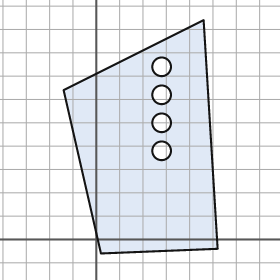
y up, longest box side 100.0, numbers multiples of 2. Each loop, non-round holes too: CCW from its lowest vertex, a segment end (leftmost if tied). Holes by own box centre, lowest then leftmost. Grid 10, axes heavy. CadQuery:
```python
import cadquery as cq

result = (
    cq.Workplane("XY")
    .moveTo(2.0, -6.0)
    .lineTo(52.0, -4.0)
    .lineTo(46.0, 94.0)
    .lineTo(-14.0, 64.0)
    .close()
    .moveTo(28.0, 38.0)
    .circle(4.0)
    .moveTo(28.0, 50.0)
    .circle(4.0)
    .moveTo(28.0, 62.0)
    .circle(4.0)
    .moveTo(28.0, 74.0)
    .circle(4.0)
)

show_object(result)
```